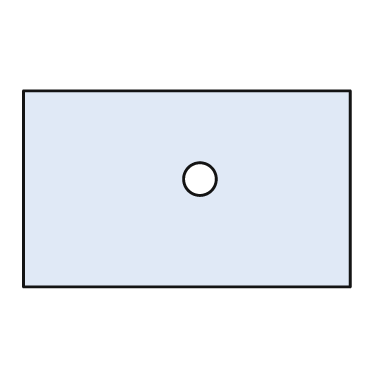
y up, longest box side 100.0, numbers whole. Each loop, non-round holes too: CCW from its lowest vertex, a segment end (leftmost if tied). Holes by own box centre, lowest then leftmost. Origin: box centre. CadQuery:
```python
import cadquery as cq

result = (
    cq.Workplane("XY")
    .moveTo(-50.0, -30.0)
    .lineTo(50.0, -30.0)
    .lineTo(50.0, 30.0)
    .lineTo(-50.0, 30.0)
    .close()
    .moveTo(4.0, 3.0)
    .circle(5.0)
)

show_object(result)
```